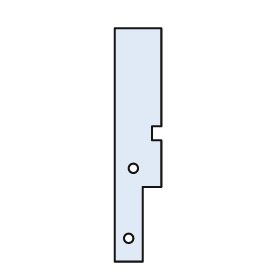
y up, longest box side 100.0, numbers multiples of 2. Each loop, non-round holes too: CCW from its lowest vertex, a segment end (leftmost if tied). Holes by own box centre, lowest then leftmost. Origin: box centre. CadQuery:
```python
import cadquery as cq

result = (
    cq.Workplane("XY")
    .moveTo(-10.0, -50.0)
    .lineTo(2.0, -50.0)
    .lineTo(2.0, -18.0)
    .lineTo(10.0, -18.0)
    .lineTo(10.0, 2.0)
    .lineTo(6.0, 2.0)
    .lineTo(6.0, 8.0)
    .lineTo(10.0, 8.0)
    .lineTo(10.0, 50.0)
    .lineTo(-10.0, 50.0)
    .close()
    .moveTo(-4.0, -40.0)
    .circle(2.0)
    .moveTo(-2.0, -10.0)
    .circle(2.0)
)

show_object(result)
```